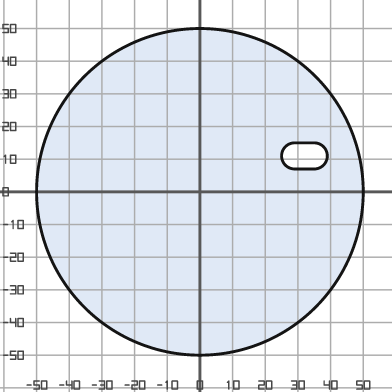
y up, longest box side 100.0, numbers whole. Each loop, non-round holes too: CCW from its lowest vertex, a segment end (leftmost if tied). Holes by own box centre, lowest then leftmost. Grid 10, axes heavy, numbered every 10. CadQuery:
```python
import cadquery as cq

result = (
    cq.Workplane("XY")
    .moveTo(0.0, 0.0)
    .circle(50.0)
    .moveTo(29.0, 7.0)
    .lineTo(35.0, 7.0)
    .threePointArc((39.0, 11.0), (35.0, 15.0))
    .lineTo(29.0, 15.0)
    .threePointArc((25.0, 11.0), (29.0, 7.0))
    .close()
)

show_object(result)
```